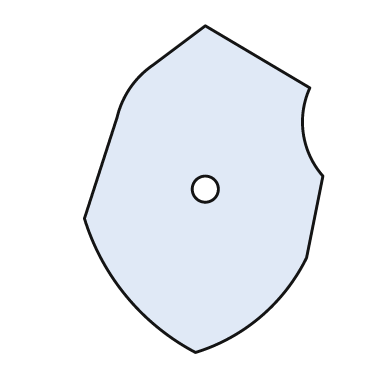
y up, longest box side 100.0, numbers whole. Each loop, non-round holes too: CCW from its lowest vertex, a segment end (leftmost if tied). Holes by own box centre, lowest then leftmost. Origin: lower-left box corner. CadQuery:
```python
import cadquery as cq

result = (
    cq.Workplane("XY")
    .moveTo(34.0, 0.0)
    .threePointArc((54.0, 11.0), (68.0, 29.0))
    .lineTo(73.0, 54.0)
    .threePointArc((67.0, 67.0), (69.0, 81.0))
    .lineTo(37.0, 100.0)
    .lineTo(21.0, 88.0)
    .threePointArc((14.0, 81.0), (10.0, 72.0))
    .lineTo(0.0, 41.0)
    .threePointArc((13.0, 17.0), (34.0, 0.0))
    .close()
    .moveTo(37.0, 50.0)
    .circle(4.0)
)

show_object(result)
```